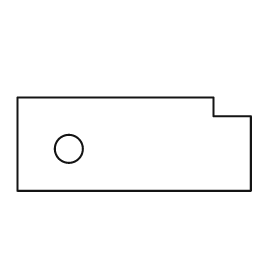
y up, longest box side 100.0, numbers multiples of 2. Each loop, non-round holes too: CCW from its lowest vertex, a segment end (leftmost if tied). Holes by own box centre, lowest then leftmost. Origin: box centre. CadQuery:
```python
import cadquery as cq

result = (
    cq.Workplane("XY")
    .moveTo(-50.0, -20.0)
    .lineTo(50.0, -20.0)
    .lineTo(50.0, 12.0)
    .lineTo(34.0, 12.0)
    .lineTo(34.0, 20.0)
    .lineTo(-50.0, 20.0)
    .close()
    .moveTo(-28.0, -2.0)
    .circle(6.0)
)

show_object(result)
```